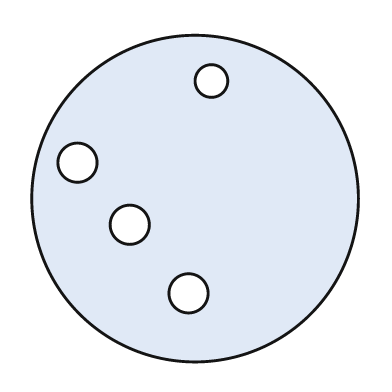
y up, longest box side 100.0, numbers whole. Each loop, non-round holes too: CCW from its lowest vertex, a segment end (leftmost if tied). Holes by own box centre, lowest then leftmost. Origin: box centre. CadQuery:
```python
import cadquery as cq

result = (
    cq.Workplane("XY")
    .moveTo(0.0, 0.0)
    .circle(50.0)
    .moveTo(-2.0, -29.0)
    .circle(6.0)
    .moveTo(-20.0, -8.0)
    .circle(6.0)
    .moveTo(-36.0, 11.0)
    .circle(6.0)
    .moveTo(5.0, 36.0)
    .circle(5.0)
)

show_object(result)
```